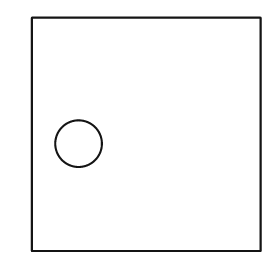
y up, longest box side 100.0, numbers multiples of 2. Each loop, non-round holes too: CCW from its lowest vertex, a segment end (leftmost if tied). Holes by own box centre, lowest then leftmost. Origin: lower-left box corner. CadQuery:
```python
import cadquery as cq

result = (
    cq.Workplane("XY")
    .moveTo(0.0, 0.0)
    .lineTo(98.0, 0.0)
    .lineTo(98.0, 100.0)
    .lineTo(0.0, 100.0)
    .close()
    .moveTo(20.0, 46.0)
    .circle(10.0)
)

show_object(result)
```